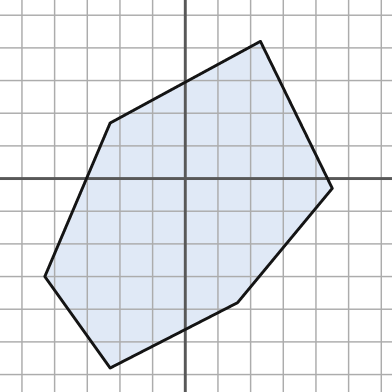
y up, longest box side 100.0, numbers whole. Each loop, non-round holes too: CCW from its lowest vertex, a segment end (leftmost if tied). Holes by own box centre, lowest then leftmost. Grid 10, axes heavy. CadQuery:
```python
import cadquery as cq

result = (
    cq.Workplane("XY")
    .moveTo(-23.0, -58.0)
    .lineTo(16.0, -38.0)
    .lineTo(45.0, -3.0)
    .lineTo(23.0, 42.0)
    .lineTo(-23.0, 17.0)
    .lineTo(-43.0, -30.0)
    .close()
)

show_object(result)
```